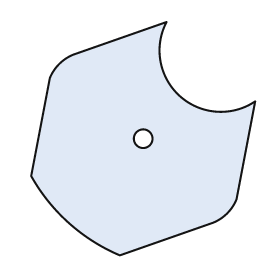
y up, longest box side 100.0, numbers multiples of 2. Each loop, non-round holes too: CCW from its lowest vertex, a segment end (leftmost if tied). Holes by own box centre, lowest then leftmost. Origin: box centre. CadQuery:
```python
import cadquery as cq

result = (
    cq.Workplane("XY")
    .moveTo(-10.0, -50.0)
    .lineTo(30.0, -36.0)
    .threePointArc((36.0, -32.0), (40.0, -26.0))
    .lineTo(48.0, 16.0)
    .threePointArc((16.0, 18.0), (10.0, 50.0))
    .lineTo(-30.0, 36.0)
    .threePointArc((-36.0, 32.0), (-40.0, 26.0))
    .lineTo(-48.0, -16.0)
    .threePointArc((-32.0, -36.0), (-10.0, -50.0))
    .close()
    .moveTo(0.0, 0.0)
    .circle(4.0)
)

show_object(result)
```